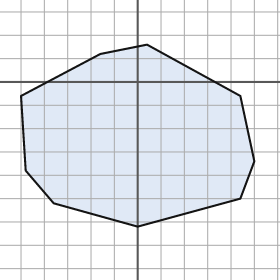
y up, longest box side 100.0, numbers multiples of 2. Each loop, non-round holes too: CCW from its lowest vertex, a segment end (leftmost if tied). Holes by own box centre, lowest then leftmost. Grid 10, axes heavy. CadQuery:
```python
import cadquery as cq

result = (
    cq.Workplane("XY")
    .moveTo(0.0, -62.0)
    .lineTo(44.0, -50.0)
    .lineTo(50.0, -34.0)
    .lineTo(44.0, -6.0)
    .lineTo(4.0, 16.0)
    .lineTo(-16.0, 12.0)
    .lineTo(-50.0, -6.0)
    .lineTo(-48.0, -38.0)
    .lineTo(-36.0, -52.0)
    .close()
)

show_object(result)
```